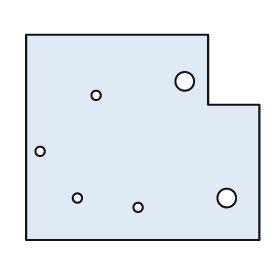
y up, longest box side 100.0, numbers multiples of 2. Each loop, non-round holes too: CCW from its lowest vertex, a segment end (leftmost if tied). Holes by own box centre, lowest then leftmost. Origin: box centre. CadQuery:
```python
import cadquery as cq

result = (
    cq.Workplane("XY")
    .moveTo(-50.0, -44.0)
    .lineTo(50.0, -44.0)
    .lineTo(50.0, 14.0)
    .lineTo(28.0, 14.0)
    .lineTo(28.0, 44.0)
    .lineTo(-50.0, 44.0)
    .close()
    .moveTo(-2.0, -30.0)
    .circle(2.0)
    .moveTo(-28.0, -26.0)
    .circle(2.0)
    .moveTo(36.0, -26.0)
    .circle(4.0)
    .moveTo(-44.0, -6.0)
    .circle(2.0)
    .moveTo(-20.0, 18.0)
    .circle(2.0)
    .moveTo(18.0, 24.0)
    .circle(4.0)
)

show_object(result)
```